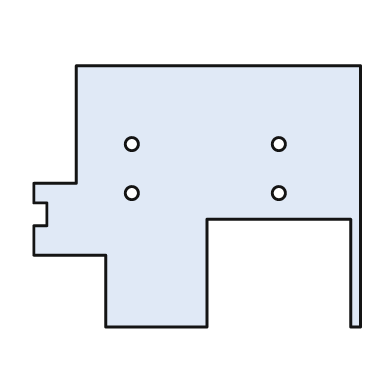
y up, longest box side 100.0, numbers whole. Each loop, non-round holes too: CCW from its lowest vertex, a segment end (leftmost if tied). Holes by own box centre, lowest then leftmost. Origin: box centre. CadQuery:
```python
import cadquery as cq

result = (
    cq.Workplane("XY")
    .moveTo(-28.0, -40.0)
    .lineTo(3.0, -40.0)
    .lineTo(3.0, -7.0)
    .lineTo(47.0, -7.0)
    .lineTo(47.0, -40.0)
    .lineTo(50.0, -40.0)
    .lineTo(50.0, 40.0)
    .lineTo(-37.0, 40.0)
    .lineTo(-37.0, 4.0)
    .lineTo(-50.0, 4.0)
    .lineTo(-50.0, -2.0)
    .lineTo(-46.0, -2.0)
    .lineTo(-46.0, -9.0)
    .lineTo(-50.0, -9.0)
    .lineTo(-50.0, -18.0)
    .lineTo(-28.0, -18.0)
    .close()
    .moveTo(-20.0, 1.0)
    .circle(2.0)
    .moveTo(25.0, 1.0)
    .circle(2.0)
    .moveTo(-20.0, 16.0)
    .circle(2.0)
    .moveTo(25.0, 16.0)
    .circle(2.0)
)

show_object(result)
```